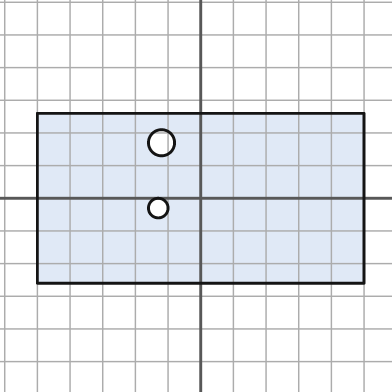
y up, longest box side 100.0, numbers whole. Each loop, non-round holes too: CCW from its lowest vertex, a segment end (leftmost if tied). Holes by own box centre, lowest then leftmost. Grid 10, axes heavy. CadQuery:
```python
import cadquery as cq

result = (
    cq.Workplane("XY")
    .moveTo(-50.0, -26.0)
    .lineTo(50.0, -26.0)
    .lineTo(50.0, 26.0)
    .lineTo(-50.0, 26.0)
    .close()
    .moveTo(-13.0, -3.0)
    .circle(3.0)
    .moveTo(-12.0, 17.0)
    .circle(4.0)
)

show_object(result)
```